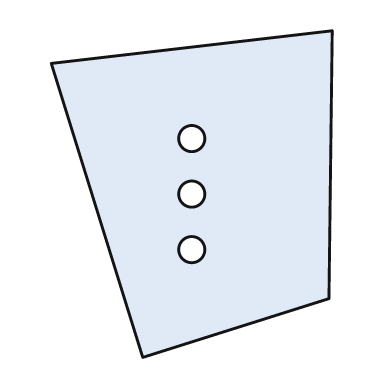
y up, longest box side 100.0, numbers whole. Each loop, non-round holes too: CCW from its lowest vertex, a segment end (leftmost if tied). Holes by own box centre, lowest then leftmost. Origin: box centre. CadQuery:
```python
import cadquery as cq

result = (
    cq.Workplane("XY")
    .moveTo(-15.0, -50.0)
    .lineTo(42.0, -32.0)
    .lineTo(43.0, 50.0)
    .lineTo(-43.0, 40.0)
    .close()
    .moveTo(0.0, -17.0)
    .circle(4.0)
    .moveTo(0.0, 0.0)
    .circle(4.0)
    .moveTo(0.0, 17.0)
    .circle(4.0)
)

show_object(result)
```